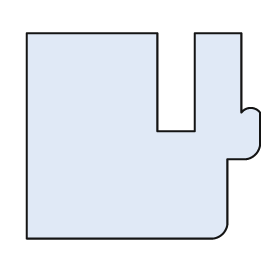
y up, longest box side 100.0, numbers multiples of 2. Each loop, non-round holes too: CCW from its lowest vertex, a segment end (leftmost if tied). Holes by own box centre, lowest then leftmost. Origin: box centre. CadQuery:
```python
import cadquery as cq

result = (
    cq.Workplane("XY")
    .moveTo(-50.0, -44.0)
    .lineTo(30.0, -44.0)
    .threePointArc((34.0, -42.0), (36.0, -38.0))
    .lineTo(36.0, -10.0)
    .lineTo(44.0, -10.0)
    .threePointArc((48.0, -8.0), (50.0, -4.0))
    .lineTo(50.0, 10.0)
    .threePointArc((46.0, 12.0), (42.0, 10.0))
    .lineTo(42.0, 44.0)
    .lineTo(22.0, 44.0)
    .lineTo(22.0, 2.0)
    .lineTo(6.0, 2.0)
    .lineTo(6.0, 44.0)
    .lineTo(-50.0, 44.0)
    .close()
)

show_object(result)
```